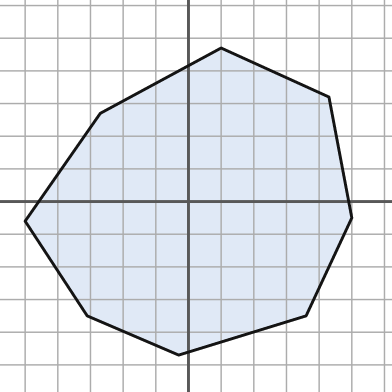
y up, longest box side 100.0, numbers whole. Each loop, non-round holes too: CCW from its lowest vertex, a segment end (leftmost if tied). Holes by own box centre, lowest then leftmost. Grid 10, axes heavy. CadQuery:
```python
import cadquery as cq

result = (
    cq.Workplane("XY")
    .moveTo(-3.0, -47.0)
    .lineTo(36.0, -35.0)
    .lineTo(50.0, -5.0)
    .lineTo(43.0, 32.0)
    .lineTo(10.0, 47.0)
    .lineTo(-27.0, 27.0)
    .lineTo(-50.0, -6.0)
    .lineTo(-31.0, -35.0)
    .close()
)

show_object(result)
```